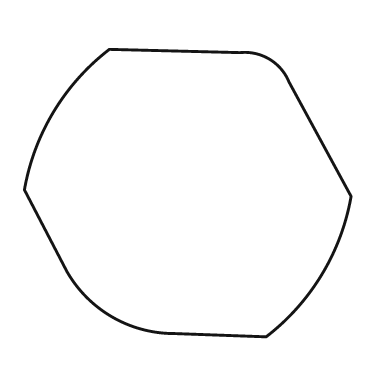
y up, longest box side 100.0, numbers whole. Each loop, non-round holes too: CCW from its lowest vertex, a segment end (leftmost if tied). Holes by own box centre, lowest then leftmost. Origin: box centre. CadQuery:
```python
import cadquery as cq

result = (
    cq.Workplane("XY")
    .moveTo(24.0, -44.0)
    .threePointArc((41.0, -25.0), (50.0, -1.0))
    .lineTo(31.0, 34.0)
    .threePointArc((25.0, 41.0), (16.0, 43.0))
    .lineTo(-24.0, 44.0)
    .threePointArc((-41.0, 25.0), (-50.0, 1.0))
    .lineTo(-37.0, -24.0)
    .threePointArc((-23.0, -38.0), (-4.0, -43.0))
    .close()
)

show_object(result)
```